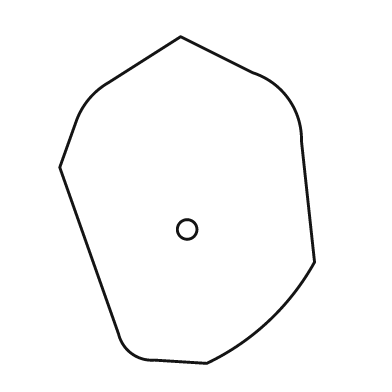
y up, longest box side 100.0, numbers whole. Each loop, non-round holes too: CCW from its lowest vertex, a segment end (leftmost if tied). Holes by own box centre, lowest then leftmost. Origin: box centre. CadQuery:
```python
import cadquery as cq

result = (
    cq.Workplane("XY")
    .moveTo(6.0, -50.0)
    .threePointArc((25.0, -37.0), (39.0, -19.0))
    .lineTo(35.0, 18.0)
    .threePointArc((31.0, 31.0), (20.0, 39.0))
    .lineTo(-2.0, 50.0)
    .lineTo(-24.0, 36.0)
    .threePointArc((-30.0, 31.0), (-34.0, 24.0))
    .lineTo(-39.0, 10.0)
    .lineTo(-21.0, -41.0)
    .threePointArc((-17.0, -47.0), (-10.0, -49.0))
    .close()
    .moveTo(0.0, -9.0)
    .circle(3.0)
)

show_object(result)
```